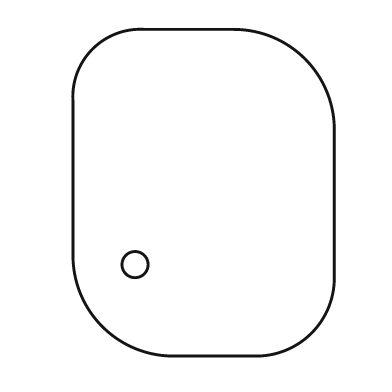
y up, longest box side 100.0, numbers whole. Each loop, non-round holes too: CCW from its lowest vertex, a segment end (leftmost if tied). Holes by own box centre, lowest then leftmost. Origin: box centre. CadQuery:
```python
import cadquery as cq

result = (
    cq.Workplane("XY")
    .moveTo(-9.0, -50.0)
    .lineTo(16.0, -50.0)
    .threePointArc((33.0, -43.0), (40.0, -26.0))
    .lineTo(40.0, 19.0)
    .threePointArc((31.0, 41.0), (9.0, 50.0))
    .lineTo(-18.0, 50.0)
    .threePointArc((-34.0, 44.0), (-40.0, 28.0))
    .lineTo(-40.0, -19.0)
    .threePointArc((-31.0, -41.0), (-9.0, -50.0))
    .close()
    .moveTo(-21.0, -22.0)
    .circle(4.0)
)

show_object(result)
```